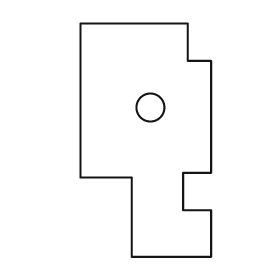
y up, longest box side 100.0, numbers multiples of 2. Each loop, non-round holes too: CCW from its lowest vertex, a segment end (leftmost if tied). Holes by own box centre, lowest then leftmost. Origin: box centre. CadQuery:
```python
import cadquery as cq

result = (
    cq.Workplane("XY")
    .moveTo(-6.0, -50.0)
    .lineTo(28.0, -50.0)
    .lineTo(28.0, -30.0)
    .lineTo(16.0, -30.0)
    .lineTo(16.0, -14.0)
    .lineTo(28.0, -14.0)
    .lineTo(28.0, 34.0)
    .lineTo(18.0, 34.0)
    .lineTo(18.0, 50.0)
    .lineTo(-28.0, 50.0)
    .lineTo(-28.0, -16.0)
    .lineTo(-6.0, -16.0)
    .close()
    .moveTo(2.0, 14.0)
    .circle(6.0)
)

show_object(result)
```